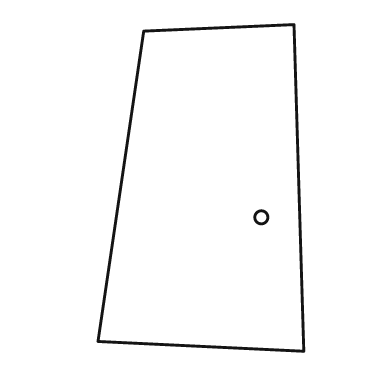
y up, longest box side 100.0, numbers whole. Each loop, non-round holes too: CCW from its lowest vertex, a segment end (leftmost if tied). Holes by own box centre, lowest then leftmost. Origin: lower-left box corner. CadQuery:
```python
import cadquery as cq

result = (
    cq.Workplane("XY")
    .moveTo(63.0, 0.0)
    .lineTo(60.0, 100.0)
    .lineTo(14.0, 98.0)
    .lineTo(0.0, 3.0)
    .close()
    .moveTo(50.0, 41.0)
    .circle(2.0)
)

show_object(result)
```